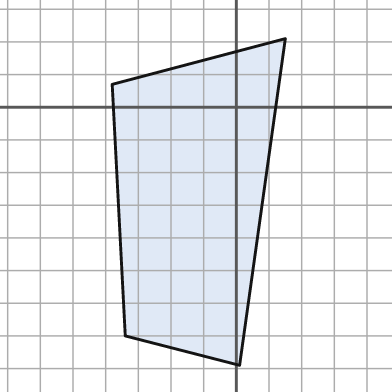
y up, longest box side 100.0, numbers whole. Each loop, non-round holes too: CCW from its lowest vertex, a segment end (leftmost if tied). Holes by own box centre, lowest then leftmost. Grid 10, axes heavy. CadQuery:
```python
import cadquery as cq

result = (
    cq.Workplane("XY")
    .moveTo(1.0, -79.0)
    .lineTo(15.0, 21.0)
    .lineTo(-38.0, 7.0)
    .lineTo(-34.0, -70.0)
    .close()
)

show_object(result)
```